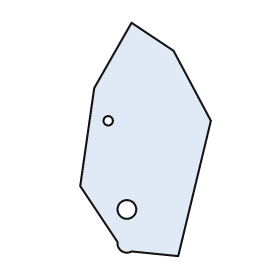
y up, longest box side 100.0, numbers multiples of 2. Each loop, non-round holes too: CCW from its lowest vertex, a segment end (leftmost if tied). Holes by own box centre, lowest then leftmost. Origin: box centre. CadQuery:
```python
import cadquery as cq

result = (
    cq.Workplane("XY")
    .moveTo(14.0, -50.0)
    .lineTo(28.0, 8.0)
    .lineTo(12.0, 38.0)
    .lineTo(-6.0, 50.0)
    .lineTo(-22.0, 22.0)
    .lineTo(-28.0, -20.0)
    .lineTo(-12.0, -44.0)
    .threePointArc((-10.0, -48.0), (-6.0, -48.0))
    .close()
    .moveTo(-8.0, -30.0)
    .circle(4.0)
    .moveTo(-16.0, 8.0)
    .circle(2.0)
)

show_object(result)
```